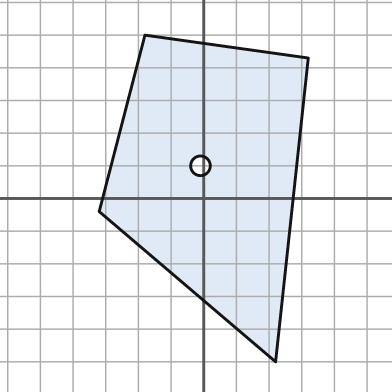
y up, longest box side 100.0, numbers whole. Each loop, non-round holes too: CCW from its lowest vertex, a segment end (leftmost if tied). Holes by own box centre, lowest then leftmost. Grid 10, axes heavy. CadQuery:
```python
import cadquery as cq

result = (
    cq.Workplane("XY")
    .moveTo(22.0, -50.0)
    .lineTo(32.0, 43.0)
    .lineTo(-18.0, 50.0)
    .lineTo(-32.0, -4.0)
    .close()
    .moveTo(-1.0, 10.0)
    .circle(3.0)
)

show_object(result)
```